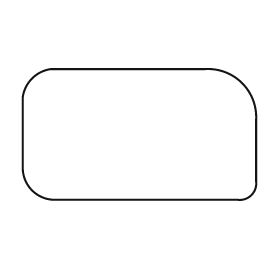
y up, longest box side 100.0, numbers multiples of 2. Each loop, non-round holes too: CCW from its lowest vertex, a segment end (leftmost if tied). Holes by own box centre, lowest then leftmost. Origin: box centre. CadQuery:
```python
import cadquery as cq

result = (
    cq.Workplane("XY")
    .moveTo(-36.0, -28.0)
    .lineTo(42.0, -28.0)
    .threePointArc((48.0, -26.0), (50.0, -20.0))
    .lineTo(50.0, 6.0)
    .threePointArc((44.0, 22.0), (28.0, 28.0))
    .lineTo(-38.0, 28.0)
    .threePointArc((-46.0, 24.0), (-50.0, 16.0))
    .lineTo(-50.0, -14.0)
    .threePointArc((-46.0, -24.0), (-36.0, -28.0))
    .close()
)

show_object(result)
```